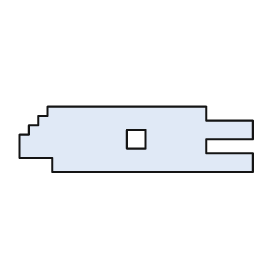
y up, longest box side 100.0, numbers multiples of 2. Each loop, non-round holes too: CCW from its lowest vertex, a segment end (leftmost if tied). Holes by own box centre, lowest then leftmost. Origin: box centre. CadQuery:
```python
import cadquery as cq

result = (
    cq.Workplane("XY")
    .moveTo(-36.0, -14.0)
    .lineTo(50.0, -14.0)
    .lineTo(50.0, -6.0)
    .lineTo(30.0, -6.0)
    .lineTo(30.0, 0.0)
    .lineTo(50.0, 0.0)
    .lineTo(50.0, 8.0)
    .lineTo(30.0, 8.0)
    .lineTo(30.0, 14.0)
    .lineTo(-38.0, 14.0)
    .lineTo(-38.0, 10.0)
    .lineTo(-42.0, 10.0)
    .lineTo(-42.0, 6.0)
    .lineTo(-46.0, 6.0)
    .lineTo(-46.0, 2.0)
    .lineTo(-50.0, 2.0)
    .lineTo(-50.0, -8.0)
    .lineTo(-36.0, -8.0)
    .close()
    .moveTo(-4.0, -4.0)
    .lineTo(4.0, -4.0)
    .lineTo(4.0, 4.0)
    .lineTo(-4.0, 4.0)
    .close()
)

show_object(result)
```